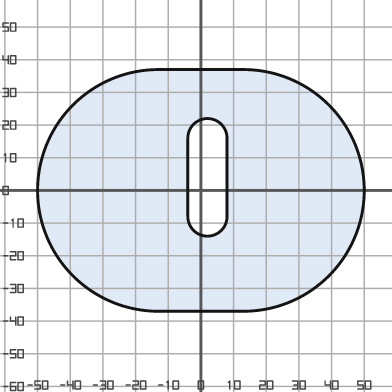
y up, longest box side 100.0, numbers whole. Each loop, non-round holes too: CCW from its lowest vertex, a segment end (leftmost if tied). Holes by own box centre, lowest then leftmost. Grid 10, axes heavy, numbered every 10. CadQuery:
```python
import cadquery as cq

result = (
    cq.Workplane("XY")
    .moveTo(-13.0, -37.0)
    .lineTo(13.0, -37.0)
    .threePointArc((50.0, 0.0), (13.0, 37.0))
    .lineTo(-13.0, 37.0)
    .threePointArc((-50.0, 0.0), (-13.0, -37.0))
    .close()
    .moveTo(-4.0, -8.0)
    .threePointArc((2.0, -14.0), (8.0, -8.0))
    .lineTo(8.0, 16.0)
    .threePointArc((2.0, 22.0), (-4.0, 16.0))
    .close()
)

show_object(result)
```